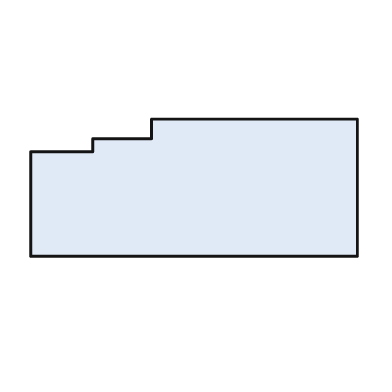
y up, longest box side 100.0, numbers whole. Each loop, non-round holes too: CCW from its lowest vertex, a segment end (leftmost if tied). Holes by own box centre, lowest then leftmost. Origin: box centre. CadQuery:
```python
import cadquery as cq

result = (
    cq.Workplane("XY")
    .moveTo(-50.0, -21.0)
    .lineTo(50.0, -21.0)
    .lineTo(50.0, 21.0)
    .lineTo(-13.0, 21.0)
    .lineTo(-13.0, 15.0)
    .lineTo(-31.0, 15.0)
    .lineTo(-31.0, 11.0)
    .lineTo(-50.0, 11.0)
    .close()
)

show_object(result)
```